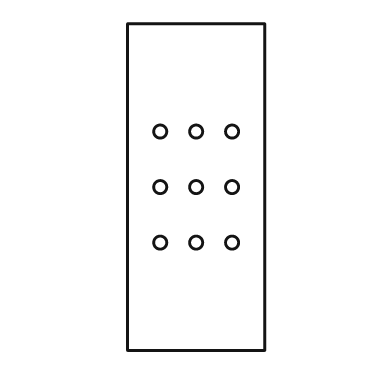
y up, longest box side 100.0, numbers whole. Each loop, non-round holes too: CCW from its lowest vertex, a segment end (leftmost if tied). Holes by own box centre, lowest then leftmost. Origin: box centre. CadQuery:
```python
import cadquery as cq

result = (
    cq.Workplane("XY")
    .moveTo(-21.0, -50.0)
    .lineTo(21.0, -50.0)
    .lineTo(21.0, 50.0)
    .lineTo(-21.0, 50.0)
    .close()
    .moveTo(-11.0, -17.0)
    .circle(2.0)
    .moveTo(0.0, -17.0)
    .circle(2.0)
    .moveTo(11.0, -17.0)
    .circle(2.0)
    .moveTo(-11.0, 0.0)
    .circle(2.0)
    .moveTo(0.0, 0.0)
    .circle(2.0)
    .moveTo(11.0, 0.0)
    .circle(2.0)
    .moveTo(-11.0, 17.0)
    .circle(2.0)
    .moveTo(0.0, 17.0)
    .circle(2.0)
    .moveTo(11.0, 17.0)
    .circle(2.0)
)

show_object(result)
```